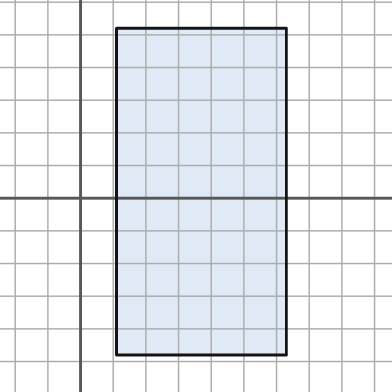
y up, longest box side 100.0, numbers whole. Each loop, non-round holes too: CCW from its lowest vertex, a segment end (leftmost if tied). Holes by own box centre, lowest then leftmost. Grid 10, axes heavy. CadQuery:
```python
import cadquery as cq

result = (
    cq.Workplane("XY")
    .moveTo(11.0, -48.0)
    .lineTo(63.0, -48.0)
    .lineTo(63.0, 52.0)
    .lineTo(11.0, 52.0)
    .close()
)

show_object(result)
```